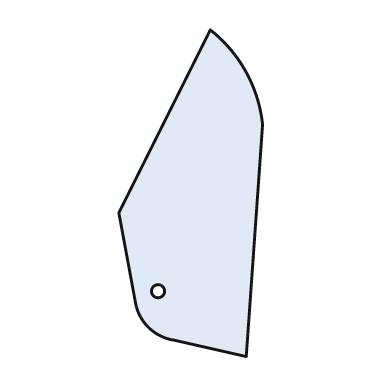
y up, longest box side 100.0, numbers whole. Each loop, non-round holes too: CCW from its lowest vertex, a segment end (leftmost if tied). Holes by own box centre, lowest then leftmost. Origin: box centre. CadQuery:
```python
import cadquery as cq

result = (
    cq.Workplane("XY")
    .moveTo(17.0, -50.0)
    .lineTo(22.0, 21.0)
    .threePointArc((17.0, 37.0), (6.0, 50.0))
    .lineTo(-22.0, -6.0)
    .lineTo(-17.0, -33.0)
    .threePointArc((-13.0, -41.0), (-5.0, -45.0))
    .close()
    .moveTo(-10.0, -30.0)
    .circle(2.0)
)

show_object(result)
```